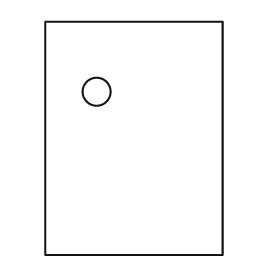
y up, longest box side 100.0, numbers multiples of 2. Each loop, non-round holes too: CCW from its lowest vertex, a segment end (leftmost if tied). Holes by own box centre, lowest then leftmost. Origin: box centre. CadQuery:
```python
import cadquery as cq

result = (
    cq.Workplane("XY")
    .moveTo(-38.0, -50.0)
    .lineTo(38.0, -50.0)
    .lineTo(38.0, 50.0)
    .lineTo(-38.0, 50.0)
    .close()
    .moveTo(-16.0, 20.0)
    .circle(6.0)
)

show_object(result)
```